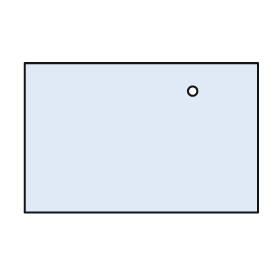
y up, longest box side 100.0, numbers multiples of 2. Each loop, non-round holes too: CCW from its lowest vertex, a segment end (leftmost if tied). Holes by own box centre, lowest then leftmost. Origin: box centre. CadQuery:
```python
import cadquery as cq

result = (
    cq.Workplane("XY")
    .moveTo(-50.0, -32.0)
    .lineTo(50.0, -32.0)
    .lineTo(50.0, 32.0)
    .lineTo(-50.0, 32.0)
    .close()
    .moveTo(22.0, 20.0)
    .circle(2.0)
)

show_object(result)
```